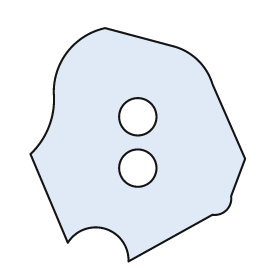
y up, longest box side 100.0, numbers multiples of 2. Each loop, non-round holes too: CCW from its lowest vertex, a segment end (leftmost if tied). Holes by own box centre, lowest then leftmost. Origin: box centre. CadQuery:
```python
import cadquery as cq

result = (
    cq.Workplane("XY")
    .moveTo(-4.0, -50.0)
    .lineTo(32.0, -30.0)
    .threePointArc((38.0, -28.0), (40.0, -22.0))
    .lineTo(46.0, -6.0)
    .lineTo(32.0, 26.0)
    .threePointArc((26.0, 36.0), (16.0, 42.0))
    .lineTo(-14.0, 50.0)
    .threePointArc((-30.0, 40.0), (-36.0, 22.0))
    .threePointArc((-38.0, 8.0), (-46.0, -4.0))
    .lineTo(-30.0, -42.0)
    .threePointArc((-14.0, -36.0), (-4.0, -50.0))
    .close()
    .moveTo(0.0, -10.0)
    .circle(8.0)
    .moveTo(0.0, 12.0)
    .circle(8.0)
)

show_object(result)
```